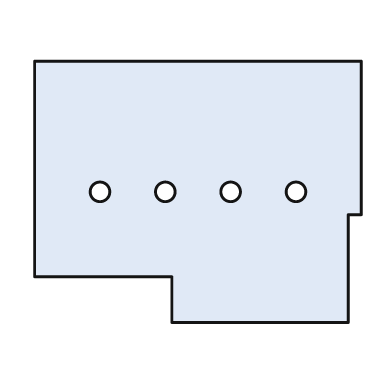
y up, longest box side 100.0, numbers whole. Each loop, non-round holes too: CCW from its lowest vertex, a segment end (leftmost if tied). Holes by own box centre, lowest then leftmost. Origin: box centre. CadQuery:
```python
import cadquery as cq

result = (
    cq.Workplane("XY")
    .moveTo(-8.0, -40.0)
    .lineTo(46.0, -40.0)
    .lineTo(46.0, -7.0)
    .lineTo(50.0, -7.0)
    .lineTo(50.0, 40.0)
    .lineTo(-50.0, 40.0)
    .lineTo(-50.0, -26.0)
    .lineTo(-8.0, -26.0)
    .close()
    .moveTo(-30.0, 0.0)
    .circle(3.0)
    .moveTo(-10.0, 0.0)
    .circle(3.0)
    .moveTo(10.0, 0.0)
    .circle(3.0)
    .moveTo(30.0, 0.0)
    .circle(3.0)
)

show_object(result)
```